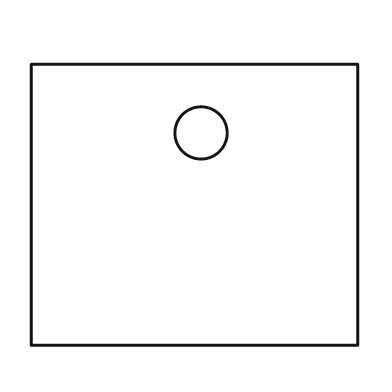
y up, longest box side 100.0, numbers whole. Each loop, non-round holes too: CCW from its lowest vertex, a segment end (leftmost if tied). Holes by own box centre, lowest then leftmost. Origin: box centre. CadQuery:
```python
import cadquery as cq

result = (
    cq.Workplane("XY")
    .moveTo(-50.0, -43.0)
    .lineTo(50.0, -43.0)
    .lineTo(50.0, 43.0)
    .lineTo(-50.0, 43.0)
    .close()
    .moveTo(2.0, 22.0)
    .circle(8.0)
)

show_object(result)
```